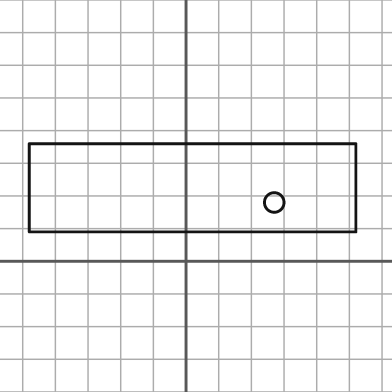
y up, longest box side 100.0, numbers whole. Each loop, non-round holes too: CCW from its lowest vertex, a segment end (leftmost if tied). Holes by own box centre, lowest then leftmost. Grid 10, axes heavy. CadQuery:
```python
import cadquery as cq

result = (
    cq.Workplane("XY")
    .moveTo(-48.0, 9.0)
    .lineTo(52.0, 9.0)
    .lineTo(52.0, 36.0)
    .lineTo(-48.0, 36.0)
    .close()
    .moveTo(27.0, 18.0)
    .circle(3.0)
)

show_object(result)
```